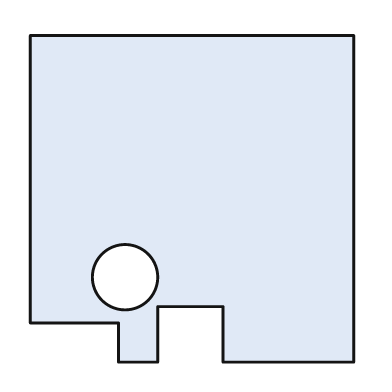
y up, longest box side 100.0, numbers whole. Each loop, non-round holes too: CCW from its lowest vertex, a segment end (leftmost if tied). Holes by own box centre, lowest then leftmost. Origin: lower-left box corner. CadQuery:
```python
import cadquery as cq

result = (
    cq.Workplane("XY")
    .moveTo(27.0, 0.0)
    .lineTo(39.0, 0.0)
    .lineTo(39.0, 17.0)
    .lineTo(59.0, 17.0)
    .lineTo(59.0, 0.0)
    .lineTo(99.0, 0.0)
    .lineTo(99.0, 100.0)
    .lineTo(0.0, 100.0)
    .lineTo(0.0, 12.0)
    .lineTo(27.0, 12.0)
    .close()
    .moveTo(29.0, 26.0)
    .circle(10.0)
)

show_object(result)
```